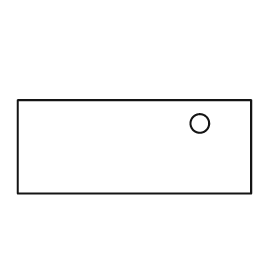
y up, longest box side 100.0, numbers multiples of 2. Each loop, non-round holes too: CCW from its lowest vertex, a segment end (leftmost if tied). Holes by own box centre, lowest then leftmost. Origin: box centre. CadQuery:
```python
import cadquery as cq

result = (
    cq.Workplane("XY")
    .moveTo(-50.0, -20.0)
    .lineTo(50.0, -20.0)
    .lineTo(50.0, 20.0)
    .lineTo(-50.0, 20.0)
    .close()
    .moveTo(28.0, 10.0)
    .circle(4.0)
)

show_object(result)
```